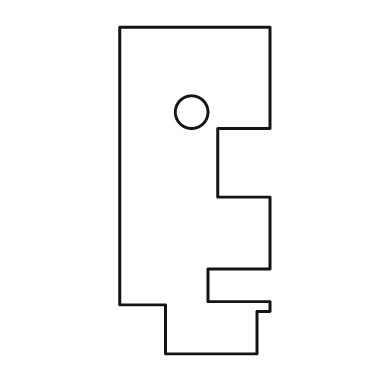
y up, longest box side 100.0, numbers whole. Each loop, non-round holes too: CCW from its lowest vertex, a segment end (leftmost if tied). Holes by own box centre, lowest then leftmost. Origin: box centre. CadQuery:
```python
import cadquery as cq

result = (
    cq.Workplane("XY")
    .moveTo(-9.0, -50.0)
    .lineTo(19.0, -50.0)
    .lineTo(19.0, -37.0)
    .lineTo(23.0, -37.0)
    .lineTo(23.0, -34.0)
    .lineTo(4.0, -34.0)
    .lineTo(4.0, -24.0)
    .lineTo(23.0, -24.0)
    .lineTo(23.0, -2.0)
    .lineTo(7.0, -2.0)
    .lineTo(7.0, 19.0)
    .lineTo(23.0, 19.0)
    .lineTo(23.0, 50.0)
    .lineTo(-23.0, 50.0)
    .lineTo(-23.0, -35.0)
    .lineTo(-9.0, -35.0)
    .close()
    .moveTo(-1.0, 24.0)
    .circle(5.0)
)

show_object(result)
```